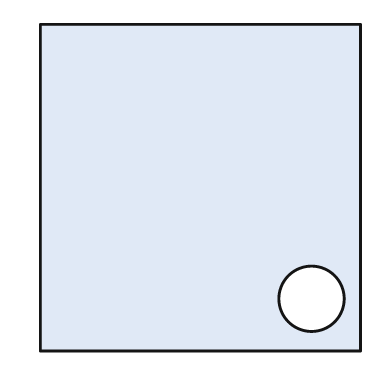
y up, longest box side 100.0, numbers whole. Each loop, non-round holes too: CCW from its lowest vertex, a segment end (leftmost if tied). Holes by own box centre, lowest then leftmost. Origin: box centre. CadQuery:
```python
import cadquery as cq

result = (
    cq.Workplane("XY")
    .moveTo(-49.0, -50.0)
    .lineTo(49.0, -50.0)
    .lineTo(49.0, 50.0)
    .lineTo(-49.0, 50.0)
    .close()
    .moveTo(34.0, -34.0)
    .circle(10.0)
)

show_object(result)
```